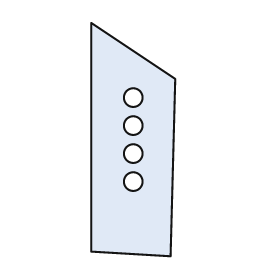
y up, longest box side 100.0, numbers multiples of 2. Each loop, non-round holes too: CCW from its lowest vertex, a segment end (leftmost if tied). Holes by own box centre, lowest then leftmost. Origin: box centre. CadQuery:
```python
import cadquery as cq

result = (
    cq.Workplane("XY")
    .moveTo(16.0, -50.0)
    .lineTo(18.0, 26.0)
    .lineTo(-18.0, 50.0)
    .lineTo(-18.0, -48.0)
    .close()
    .moveTo(0.0, -18.0)
    .circle(4.0)
    .moveTo(0.0, -6.0)
    .circle(4.0)
    .moveTo(0.0, 6.0)
    .circle(4.0)
    .moveTo(0.0, 18.0)
    .circle(4.0)
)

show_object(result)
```